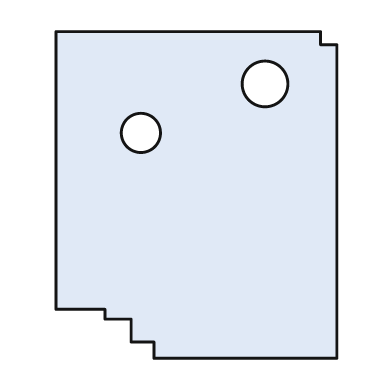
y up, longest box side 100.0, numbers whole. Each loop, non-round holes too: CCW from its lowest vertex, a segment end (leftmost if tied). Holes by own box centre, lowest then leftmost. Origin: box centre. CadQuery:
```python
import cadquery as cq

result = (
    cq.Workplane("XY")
    .moveTo(-13.0, -50.0)
    .lineTo(43.0, -50.0)
    .lineTo(43.0, 46.0)
    .lineTo(38.0, 46.0)
    .lineTo(38.0, 50.0)
    .lineTo(-43.0, 50.0)
    .lineTo(-43.0, -35.0)
    .lineTo(-28.0, -35.0)
    .lineTo(-28.0, -38.0)
    .lineTo(-20.0, -38.0)
    .lineTo(-20.0, -45.0)
    .lineTo(-13.0, -45.0)
    .close()
    .moveTo(-17.0, 19.0)
    .circle(6.0)
    .moveTo(21.0, 34.0)
    .circle(7.0)
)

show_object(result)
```